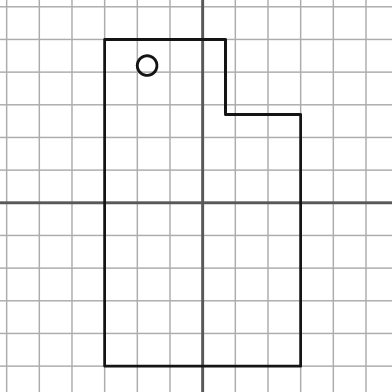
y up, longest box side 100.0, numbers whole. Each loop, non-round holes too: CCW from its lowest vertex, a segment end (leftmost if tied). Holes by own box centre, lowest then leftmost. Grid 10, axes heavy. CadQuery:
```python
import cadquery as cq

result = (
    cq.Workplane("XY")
    .moveTo(-30.0, -50.0)
    .lineTo(30.0, -50.0)
    .lineTo(30.0, 27.0)
    .lineTo(7.0, 27.0)
    .lineTo(7.0, 50.0)
    .lineTo(-30.0, 50.0)
    .close()
    .moveTo(-17.0, 42.0)
    .circle(3.0)
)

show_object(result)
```